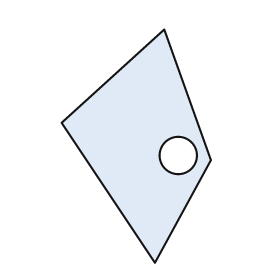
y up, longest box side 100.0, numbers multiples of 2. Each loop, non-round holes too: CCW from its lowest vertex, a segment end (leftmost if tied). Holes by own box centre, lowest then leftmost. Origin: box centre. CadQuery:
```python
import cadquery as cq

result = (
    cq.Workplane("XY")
    .moveTo(8.0, -50.0)
    .lineTo(32.0, -6.0)
    .lineTo(12.0, 50.0)
    .lineTo(-32.0, 10.0)
    .close()
    .moveTo(18.0, -4.0)
    .circle(8.0)
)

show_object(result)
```